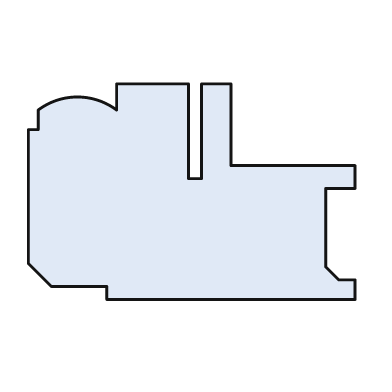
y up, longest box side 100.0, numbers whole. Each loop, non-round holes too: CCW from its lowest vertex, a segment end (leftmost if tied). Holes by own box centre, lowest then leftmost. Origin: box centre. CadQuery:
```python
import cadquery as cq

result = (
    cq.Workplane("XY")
    .moveTo(-26.0, -33.0)
    .lineTo(50.0, -33.0)
    .lineTo(50.0, -27.0)
    .lineTo(45.0, -27.0)
    .lineTo(41.0, -23.0)
    .lineTo(41.0, 1.0)
    .lineTo(50.0, 1.0)
    .lineTo(50.0, 8.0)
    .lineTo(12.0, 8.0)
    .lineTo(12.0, 33.0)
    .lineTo(3.0, 33.0)
    .lineTo(3.0, 4.0)
    .lineTo(-1.0, 4.0)
    .lineTo(-1.0, 33.0)
    .lineTo(-23.0, 33.0)
    .lineTo(-23.0, 25.0)
    .threePointArc((-35.0, 29.0), (-47.0, 25.0))
    .lineTo(-47.0, 19.0)
    .lineTo(-50.0, 19.0)
    .lineTo(-50.0, -22.0)
    .lineTo(-43.0, -29.0)
    .lineTo(-26.0, -29.0)
    .close()
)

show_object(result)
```